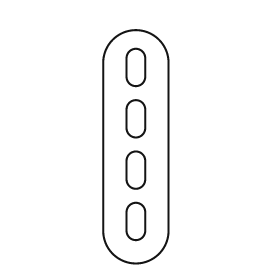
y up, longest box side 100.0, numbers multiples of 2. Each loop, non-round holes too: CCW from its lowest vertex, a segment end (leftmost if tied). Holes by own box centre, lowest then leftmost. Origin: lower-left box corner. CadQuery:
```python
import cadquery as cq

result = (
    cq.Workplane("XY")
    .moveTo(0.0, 14.0)
    .threePointArc((14.0, 0.0), (28.0, 14.0))
    .lineTo(28.0, 86.0)
    .threePointArc((14.0, 100.0), (0.0, 86.0))
    .close()
    .moveTo(10.0, 14.0)
    .threePointArc((14.0, 10.0), (18.0, 14.0))
    .lineTo(18.0, 22.0)
    .threePointArc((14.0, 26.0), (10.0, 22.0))
    .close()
    .moveTo(10.0, 36.0)
    .threePointArc((14.0, 32.0), (18.0, 36.0))
    .lineTo(18.0, 44.0)
    .threePointArc((14.0, 48.0), (10.0, 44.0))
    .close()
    .moveTo(10.0, 58.0)
    .threePointArc((14.0, 54.0), (18.0, 58.0))
    .lineTo(18.0, 66.0)
    .threePointArc((14.0, 70.0), (10.0, 66.0))
    .close()
    .moveTo(10.0, 80.0)
    .threePointArc((14.0, 76.0), (18.0, 80.0))
    .lineTo(18.0, 88.0)
    .threePointArc((14.0, 92.0), (10.0, 88.0))
    .close()
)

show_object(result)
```